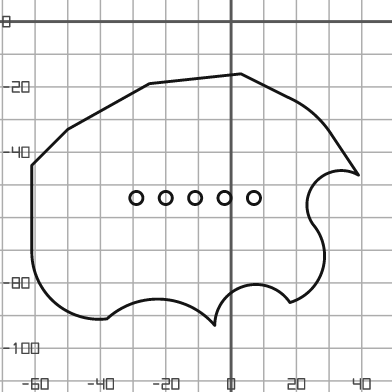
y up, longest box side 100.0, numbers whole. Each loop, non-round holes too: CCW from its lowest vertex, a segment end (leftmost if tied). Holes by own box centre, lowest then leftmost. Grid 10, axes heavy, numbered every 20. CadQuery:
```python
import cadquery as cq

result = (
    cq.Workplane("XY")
    .moveTo(-5.0, -93.0)
    .threePointArc((4.0, -81.0), (18.0, -86.0))
    .threePointArc((28.0, -76.0), (25.0, -62.0))
    .threePointArc((26.0, -49.0), (39.0, -47.0))
    .lineTo(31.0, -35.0)
    .threePointArc((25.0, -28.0), (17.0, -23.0))
    .lineTo(3.0, -16.0)
    .lineTo(-25.0, -19.0)
    .lineTo(-50.0, -33.0)
    .lineTo(-61.0, -44.0)
    .lineTo(-61.0, -71.0)
    .threePointArc((-54.0, -86.0), (-38.0, -91.0))
    .threePointArc((-21.0, -85.0), (-5.0, -93.0))
    .close()
    .moveTo(-29.0, -54.0)
    .circle(2.0)
    .moveTo(-20.0, -54.0)
    .circle(2.0)
    .moveTo(-11.0, -54.0)
    .circle(2.0)
    .moveTo(-2.0, -54.0)
    .circle(2.0)
    .moveTo(7.0, -54.0)
    .circle(2.0)
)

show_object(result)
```